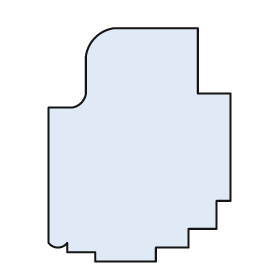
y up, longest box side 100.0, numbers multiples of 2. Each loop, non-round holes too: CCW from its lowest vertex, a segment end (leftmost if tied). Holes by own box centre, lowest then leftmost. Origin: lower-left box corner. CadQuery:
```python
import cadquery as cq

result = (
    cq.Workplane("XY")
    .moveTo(20.0, 0.0)
    .lineTo(46.0, 0.0)
    .lineTo(46.0, 6.0)
    .lineTo(60.0, 6.0)
    .lineTo(60.0, 14.0)
    .lineTo(72.0, 14.0)
    .lineTo(72.0, 26.0)
    .lineTo(78.0, 26.0)
    .lineTo(78.0, 72.0)
    .lineTo(64.0, 72.0)
    .lineTo(64.0, 100.0)
    .lineTo(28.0, 100.0)
    .threePointArc((20.0, 96.0), (16.0, 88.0))
    .lineTo(16.0, 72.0)
    .threePointArc((14.0, 68.0), (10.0, 66.0))
    .lineTo(0.0, 66.0)
    .lineTo(0.0, 8.0)
    .threePointArc((4.0, 6.0), (8.0, 8.0))
    .lineTo(8.0, 4.0)
    .lineTo(20.0, 4.0)
    .close()
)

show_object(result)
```